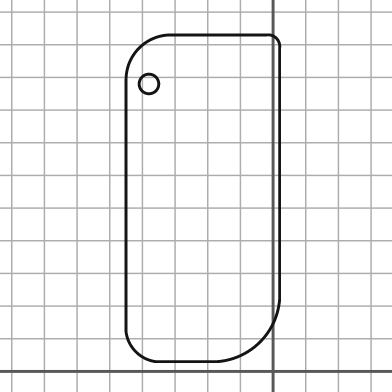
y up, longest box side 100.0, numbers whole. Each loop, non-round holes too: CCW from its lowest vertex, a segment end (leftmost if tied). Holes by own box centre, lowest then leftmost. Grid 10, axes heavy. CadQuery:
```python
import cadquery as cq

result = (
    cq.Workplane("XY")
    .moveTo(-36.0, 3.0)
    .lineTo(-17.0, 3.0)
    .threePointArc((-4.0, 9.0), (2.0, 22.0))
    .lineTo(2.0, 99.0)
    .threePointArc((1.0, 102.0), (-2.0, 103.0))
    .lineTo(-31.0, 103.0)
    .threePointArc((-41.0, 99.0), (-45.0, 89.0))
    .lineTo(-45.0, 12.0)
    .threePointArc((-42.0, 6.0), (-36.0, 3.0))
    .close()
    .moveTo(-38.0, 88.0)
    .circle(3.0)
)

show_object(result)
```